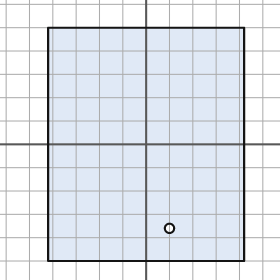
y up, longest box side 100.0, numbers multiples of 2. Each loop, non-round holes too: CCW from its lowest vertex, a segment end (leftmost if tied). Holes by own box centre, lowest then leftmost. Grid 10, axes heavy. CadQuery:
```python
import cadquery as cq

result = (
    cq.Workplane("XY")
    .moveTo(-42.0, -50.0)
    .lineTo(42.0, -50.0)
    .lineTo(42.0, 50.0)
    .lineTo(-42.0, 50.0)
    .close()
    .moveTo(10.0, -36.0)
    .circle(2.0)
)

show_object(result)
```